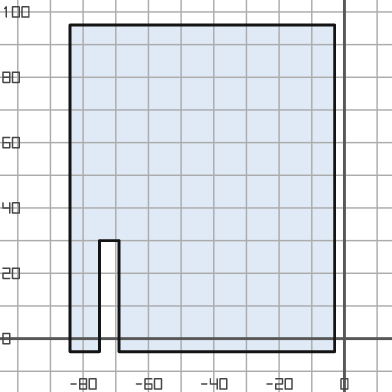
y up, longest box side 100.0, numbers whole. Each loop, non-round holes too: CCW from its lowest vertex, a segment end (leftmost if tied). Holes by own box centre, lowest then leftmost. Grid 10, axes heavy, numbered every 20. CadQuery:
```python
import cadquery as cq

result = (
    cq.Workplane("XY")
    .moveTo(-84.0, -4.0)
    .lineTo(-75.0, -4.0)
    .lineTo(-75.0, 30.0)
    .lineTo(-69.0, 30.0)
    .lineTo(-69.0, -4.0)
    .lineTo(-3.0, -4.0)
    .lineTo(-3.0, 96.0)
    .lineTo(-84.0, 96.0)
    .close()
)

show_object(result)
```